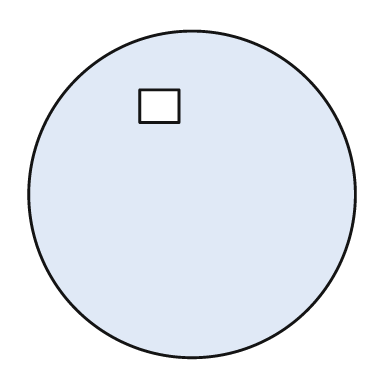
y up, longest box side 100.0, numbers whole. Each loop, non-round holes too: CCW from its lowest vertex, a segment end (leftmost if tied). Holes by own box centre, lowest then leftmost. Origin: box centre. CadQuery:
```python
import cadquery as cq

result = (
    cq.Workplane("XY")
    .moveTo(0.0, 0.0)
    .circle(50.0)
    .moveTo(-16.0, 22.0)
    .lineTo(-4.0, 22.0)
    .lineTo(-4.0, 32.0)
    .lineTo(-16.0, 32.0)
    .close()
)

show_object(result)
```